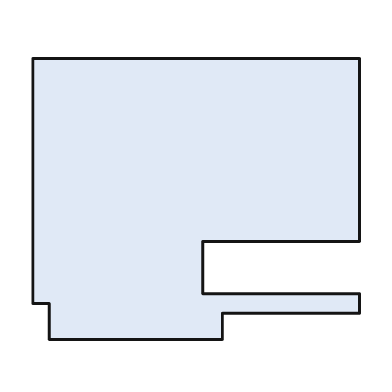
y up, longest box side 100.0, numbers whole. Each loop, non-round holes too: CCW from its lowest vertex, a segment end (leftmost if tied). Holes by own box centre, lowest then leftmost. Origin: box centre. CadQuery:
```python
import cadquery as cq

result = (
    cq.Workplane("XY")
    .moveTo(-45.0, -43.0)
    .lineTo(8.0, -43.0)
    .lineTo(8.0, -35.0)
    .lineTo(50.0, -35.0)
    .lineTo(50.0, -29.0)
    .lineTo(2.0, -29.0)
    .lineTo(2.0, -13.0)
    .lineTo(50.0, -13.0)
    .lineTo(50.0, 43.0)
    .lineTo(-50.0, 43.0)
    .lineTo(-50.0, -32.0)
    .lineTo(-45.0, -32.0)
    .close()
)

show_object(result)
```